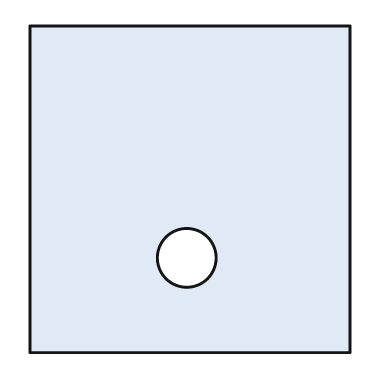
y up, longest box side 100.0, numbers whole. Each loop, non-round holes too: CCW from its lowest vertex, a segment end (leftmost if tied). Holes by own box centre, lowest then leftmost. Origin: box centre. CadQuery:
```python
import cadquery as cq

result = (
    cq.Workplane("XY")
    .moveTo(-49.0, -50.0)
    .lineTo(49.0, -50.0)
    .lineTo(49.0, 50.0)
    .lineTo(-49.0, 50.0)
    .close()
    .moveTo(-1.0, -21.0)
    .circle(9.0)
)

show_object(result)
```